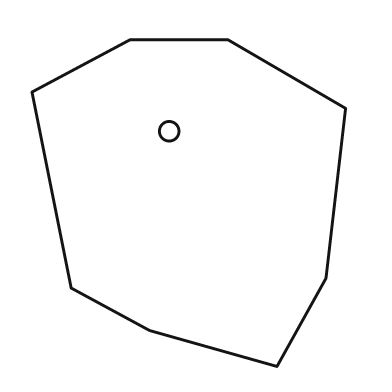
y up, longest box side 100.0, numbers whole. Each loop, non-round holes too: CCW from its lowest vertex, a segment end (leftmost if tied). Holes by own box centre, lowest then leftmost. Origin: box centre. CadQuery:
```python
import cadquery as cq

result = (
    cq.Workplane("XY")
    .moveTo(27.0, -50.0)
    .lineTo(42.0, -23.0)
    .lineTo(48.0, 29.0)
    .lineTo(12.0, 50.0)
    .lineTo(-18.0, 50.0)
    .lineTo(-48.0, 34.0)
    .lineTo(-36.0, -26.0)
    .lineTo(-12.0, -39.0)
    .close()
    .moveTo(-6.0, 22.0)
    .circle(3.0)
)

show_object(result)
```